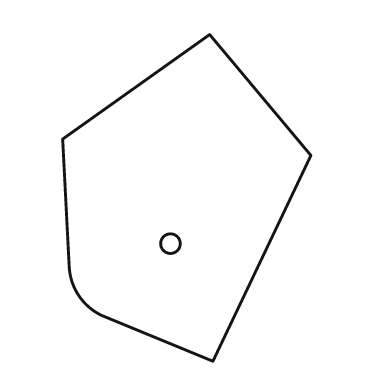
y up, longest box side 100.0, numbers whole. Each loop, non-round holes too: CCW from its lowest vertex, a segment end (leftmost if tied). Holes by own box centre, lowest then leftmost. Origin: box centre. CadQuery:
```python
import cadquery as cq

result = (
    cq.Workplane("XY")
    .moveTo(8.0, -50.0)
    .lineTo(38.0, 13.0)
    .lineTo(7.0, 50.0)
    .lineTo(-38.0, 18.0)
    .lineTo(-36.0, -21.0)
    .threePointArc((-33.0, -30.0), (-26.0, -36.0))
    .close()
    .moveTo(-5.0, -14.0)
    .circle(3.0)
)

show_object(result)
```